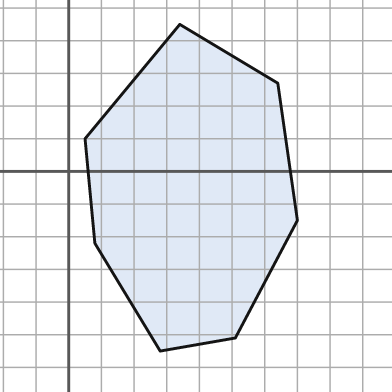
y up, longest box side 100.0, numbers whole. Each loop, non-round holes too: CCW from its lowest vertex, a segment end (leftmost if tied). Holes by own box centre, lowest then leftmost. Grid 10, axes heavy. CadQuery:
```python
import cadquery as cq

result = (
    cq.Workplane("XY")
    .moveTo(28.0, -55.0)
    .lineTo(51.0, -51.0)
    .lineTo(70.0, -15.0)
    .lineTo(64.0, 27.0)
    .lineTo(34.0, 45.0)
    .lineTo(5.0, 10.0)
    .lineTo(8.0, -22.0)
    .close()
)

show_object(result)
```